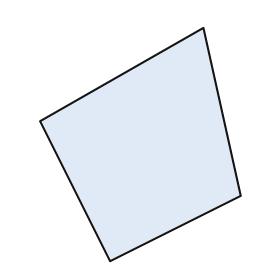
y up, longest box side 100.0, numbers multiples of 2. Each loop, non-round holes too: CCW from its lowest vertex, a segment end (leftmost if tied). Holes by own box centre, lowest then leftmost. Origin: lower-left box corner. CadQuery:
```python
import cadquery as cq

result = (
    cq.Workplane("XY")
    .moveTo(30.0, 0.0)
    .lineTo(86.0, 28.0)
    .lineTo(70.0, 100.0)
    .lineTo(0.0, 60.0)
    .close()
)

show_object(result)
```